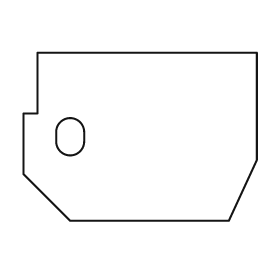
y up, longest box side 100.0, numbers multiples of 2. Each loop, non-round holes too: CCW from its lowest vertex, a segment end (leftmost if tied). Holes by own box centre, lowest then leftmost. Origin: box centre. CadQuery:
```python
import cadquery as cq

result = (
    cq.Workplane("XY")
    .moveTo(-30.0, -36.0)
    .lineTo(38.0, -36.0)
    .lineTo(50.0, -10.0)
    .lineTo(50.0, 36.0)
    .lineTo(-44.0, 36.0)
    .lineTo(-44.0, 10.0)
    .lineTo(-50.0, 10.0)
    .lineTo(-50.0, -16.0)
    .close()
    .moveTo(-36.0, -2.0)
    .threePointArc((-30.0, -8.0), (-24.0, -2.0))
    .lineTo(-24.0, 2.0)
    .threePointArc((-30.0, 8.0), (-36.0, 2.0))
    .close()
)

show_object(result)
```